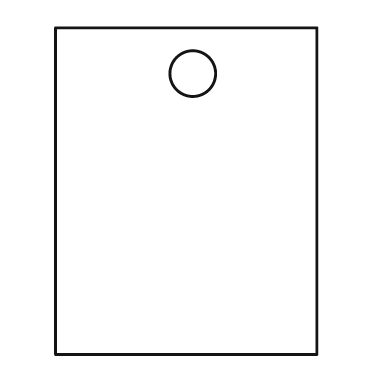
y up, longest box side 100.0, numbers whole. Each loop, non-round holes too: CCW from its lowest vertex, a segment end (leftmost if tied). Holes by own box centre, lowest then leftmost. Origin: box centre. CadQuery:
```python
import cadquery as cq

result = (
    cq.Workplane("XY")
    .moveTo(-40.0, -50.0)
    .lineTo(40.0, -50.0)
    .lineTo(40.0, 50.0)
    .lineTo(-40.0, 50.0)
    .close()
    .moveTo(2.0, 36.0)
    .circle(7.0)
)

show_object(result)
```